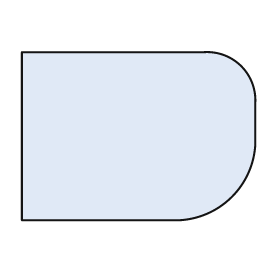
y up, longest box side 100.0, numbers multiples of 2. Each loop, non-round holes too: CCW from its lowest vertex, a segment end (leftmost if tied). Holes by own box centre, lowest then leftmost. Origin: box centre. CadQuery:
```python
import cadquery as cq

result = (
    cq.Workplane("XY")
    .moveTo(-50.0, -36.0)
    .lineTo(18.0, -36.0)
    .threePointArc((40.0, -26.0), (50.0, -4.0))
    .lineTo(50.0, 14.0)
    .threePointArc((44.0, 30.0), (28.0, 36.0))
    .lineTo(-50.0, 36.0)
    .close()
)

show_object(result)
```